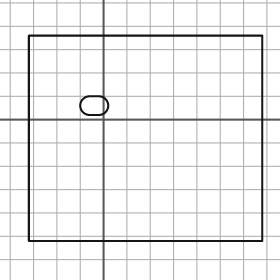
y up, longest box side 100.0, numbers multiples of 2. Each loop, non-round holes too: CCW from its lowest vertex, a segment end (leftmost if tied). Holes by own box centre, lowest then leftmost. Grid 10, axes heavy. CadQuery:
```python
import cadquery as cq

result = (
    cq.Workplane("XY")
    .moveTo(-32.0, -52.0)
    .lineTo(68.0, -52.0)
    .lineTo(68.0, 36.0)
    .lineTo(-32.0, 36.0)
    .close()
    .moveTo(-6.0, 2.0)
    .lineTo(-2.0, 2.0)
    .threePointArc((2.0, 6.0), (-2.0, 10.0))
    .lineTo(-6.0, 10.0)
    .threePointArc((-10.0, 6.0), (-6.0, 2.0))
    .close()
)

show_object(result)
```